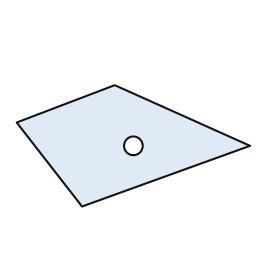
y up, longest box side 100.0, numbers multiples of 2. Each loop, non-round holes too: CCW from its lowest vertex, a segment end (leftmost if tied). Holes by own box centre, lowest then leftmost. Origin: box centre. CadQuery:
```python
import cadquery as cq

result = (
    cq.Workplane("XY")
    .moveTo(-22.0, -26.0)
    .lineTo(50.0, 0.0)
    .lineTo(-8.0, 26.0)
    .lineTo(-50.0, 10.0)
    .close()
    .moveTo(0.0, 0.0)
    .circle(4.0)
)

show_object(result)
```